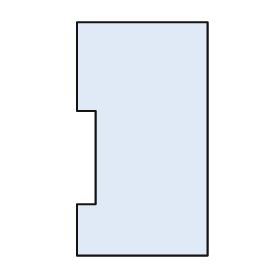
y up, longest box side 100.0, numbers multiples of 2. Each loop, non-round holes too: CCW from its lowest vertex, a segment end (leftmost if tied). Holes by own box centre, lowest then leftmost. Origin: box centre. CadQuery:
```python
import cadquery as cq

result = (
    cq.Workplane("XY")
    .moveTo(-28.0, -50.0)
    .lineTo(28.0, -50.0)
    .lineTo(28.0, 50.0)
    .lineTo(-28.0, 50.0)
    .lineTo(-28.0, 12.0)
    .lineTo(-20.0, 12.0)
    .lineTo(-20.0, -28.0)
    .lineTo(-28.0, -28.0)
    .close()
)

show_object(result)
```